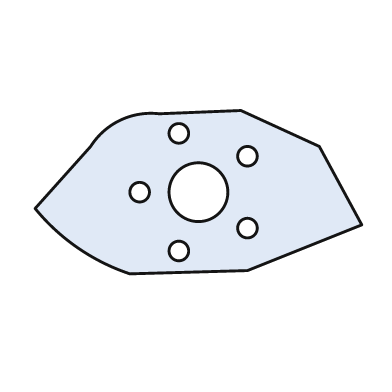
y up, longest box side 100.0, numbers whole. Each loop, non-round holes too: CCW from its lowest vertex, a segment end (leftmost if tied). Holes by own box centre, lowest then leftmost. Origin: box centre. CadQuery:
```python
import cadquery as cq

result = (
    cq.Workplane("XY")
    .moveTo(-21.0, -25.0)
    .lineTo(15.0, -24.0)
    .lineTo(50.0, -10.0)
    .lineTo(37.0, 14.0)
    .lineTo(13.0, 25.0)
    .lineTo(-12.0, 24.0)
    .threePointArc((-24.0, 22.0), (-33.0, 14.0))
    .lineTo(-50.0, -5.0)
    .threePointArc((-37.0, -17.0), (-21.0, -25.0))
    .close()
    .moveTo(-6.0, -18.0)
    .circle(3.0)
    .moveTo(15.0, -11.0)
    .circle(3.0)
    .moveTo(-18.0, 0.0)
    .circle(3.0)
    .moveTo(0.0, 0.0)
    .circle(9.0)
    .moveTo(15.0, 11.0)
    .circle(3.0)
    .moveTo(-6.0, 18.0)
    .circle(3.0)
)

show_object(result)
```